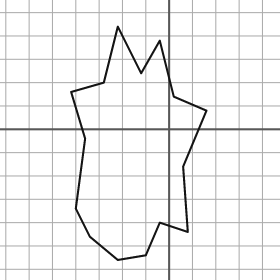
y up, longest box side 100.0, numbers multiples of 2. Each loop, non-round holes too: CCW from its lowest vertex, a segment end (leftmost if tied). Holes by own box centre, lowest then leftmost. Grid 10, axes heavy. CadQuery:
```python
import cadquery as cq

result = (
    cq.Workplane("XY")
    .moveTo(-22.0, -56.0)
    .lineTo(-10.0, -54.0)
    .lineTo(-4.0, -40.0)
    .lineTo(8.0, -44.0)
    .lineTo(6.0, -16.0)
    .lineTo(16.0, 8.0)
    .lineTo(2.0, 14.0)
    .lineTo(-4.0, 38.0)
    .lineTo(-12.0, 24.0)
    .lineTo(-22.0, 44.0)
    .lineTo(-28.0, 20.0)
    .lineTo(-42.0, 16.0)
    .lineTo(-36.0, -4.0)
    .lineTo(-40.0, -34.0)
    .lineTo(-34.0, -46.0)
    .close()
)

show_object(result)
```